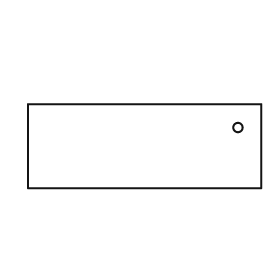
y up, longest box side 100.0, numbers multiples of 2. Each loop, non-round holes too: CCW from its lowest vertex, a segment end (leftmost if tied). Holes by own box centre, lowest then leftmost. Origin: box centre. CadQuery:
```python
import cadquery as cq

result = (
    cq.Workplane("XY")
    .moveTo(-50.0, -18.0)
    .lineTo(50.0, -18.0)
    .lineTo(50.0, 18.0)
    .lineTo(-50.0, 18.0)
    .close()
    .moveTo(40.0, 8.0)
    .circle(2.0)
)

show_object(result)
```